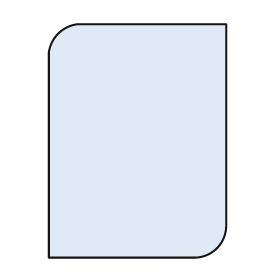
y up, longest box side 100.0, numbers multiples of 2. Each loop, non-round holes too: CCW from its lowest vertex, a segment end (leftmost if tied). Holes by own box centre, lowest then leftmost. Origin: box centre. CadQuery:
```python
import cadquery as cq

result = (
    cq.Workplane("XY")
    .moveTo(-38.0, -50.0)
    .lineTo(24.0, -50.0)
    .threePointArc((34.0, -46.0), (38.0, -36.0))
    .lineTo(38.0, 50.0)
    .lineTo(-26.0, 50.0)
    .threePointArc((-34.0, 46.0), (-38.0, 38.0))
    .close()
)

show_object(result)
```